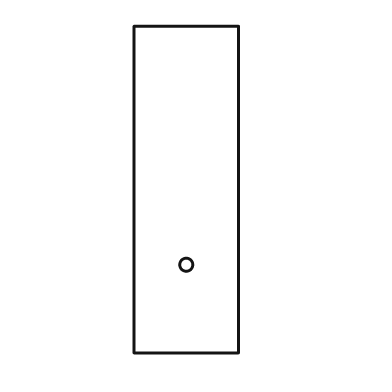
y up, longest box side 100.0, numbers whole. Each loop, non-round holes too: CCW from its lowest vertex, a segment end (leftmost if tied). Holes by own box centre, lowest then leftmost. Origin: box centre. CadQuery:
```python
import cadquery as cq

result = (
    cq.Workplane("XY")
    .moveTo(-16.0, -50.0)
    .lineTo(16.0, -50.0)
    .lineTo(16.0, 50.0)
    .lineTo(-16.0, 50.0)
    .close()
    .moveTo(0.0, -23.0)
    .circle(2.0)
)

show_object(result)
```